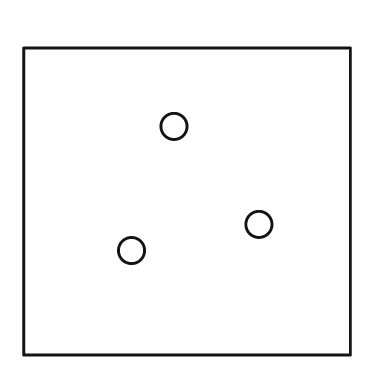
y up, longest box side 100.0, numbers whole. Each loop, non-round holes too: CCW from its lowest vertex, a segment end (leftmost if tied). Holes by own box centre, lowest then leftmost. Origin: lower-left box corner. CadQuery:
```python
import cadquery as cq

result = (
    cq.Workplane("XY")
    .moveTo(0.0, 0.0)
    .lineTo(100.0, 0.0)
    .lineTo(100.0, 94.0)
    .lineTo(0.0, 94.0)
    .close()
    .moveTo(33.0, 32.0)
    .circle(4.0)
    .moveTo(72.0, 40.0)
    .circle(4.0)
    .moveTo(46.0, 70.0)
    .circle(4.0)
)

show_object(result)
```